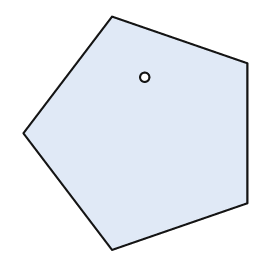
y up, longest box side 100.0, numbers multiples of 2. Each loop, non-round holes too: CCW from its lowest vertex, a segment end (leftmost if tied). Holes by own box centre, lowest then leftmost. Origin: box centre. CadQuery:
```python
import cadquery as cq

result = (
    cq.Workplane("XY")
    .moveTo(-10.0, -50.0)
    .lineTo(48.0, -30.0)
    .lineTo(48.0, 30.0)
    .lineTo(-10.0, 50.0)
    .lineTo(-48.0, 0.0)
    .close()
    .moveTo(4.0, 24.0)
    .circle(2.0)
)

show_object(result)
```